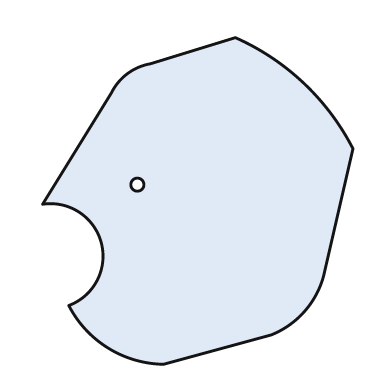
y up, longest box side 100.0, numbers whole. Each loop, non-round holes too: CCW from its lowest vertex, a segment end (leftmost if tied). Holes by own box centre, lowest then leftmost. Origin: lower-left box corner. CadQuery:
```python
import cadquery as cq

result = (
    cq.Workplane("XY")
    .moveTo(37.0, 0.0)
    .lineTo(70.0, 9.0)
    .threePointArc((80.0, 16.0), (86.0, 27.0))
    .lineTo(95.0, 66.0)
    .threePointArc((80.0, 86.0), (59.0, 100.0))
    .lineTo(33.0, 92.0)
    .threePointArc((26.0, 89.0), (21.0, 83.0))
    .lineTo(0.0, 49.0)
    .threePointArc((18.0, 37.0), (8.0, 18.0))
    .threePointArc((20.0, 5.0), (37.0, 0.0))
    .close()
    .moveTo(29.0, 55.0)
    .circle(2.0)
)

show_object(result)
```